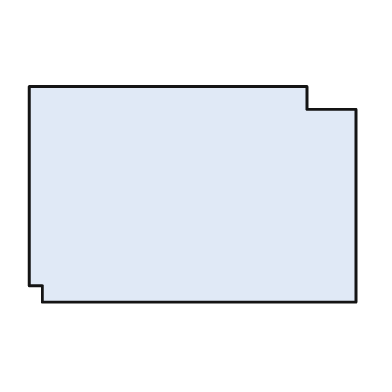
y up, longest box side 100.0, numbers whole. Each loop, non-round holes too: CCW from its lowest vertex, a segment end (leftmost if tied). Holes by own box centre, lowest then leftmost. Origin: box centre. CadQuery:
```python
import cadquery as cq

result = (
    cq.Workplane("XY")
    .moveTo(-46.0, -33.0)
    .lineTo(50.0, -33.0)
    .lineTo(50.0, 26.0)
    .lineTo(35.0, 26.0)
    .lineTo(35.0, 33.0)
    .lineTo(-50.0, 33.0)
    .lineTo(-50.0, -28.0)
    .lineTo(-46.0, -28.0)
    .close()
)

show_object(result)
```